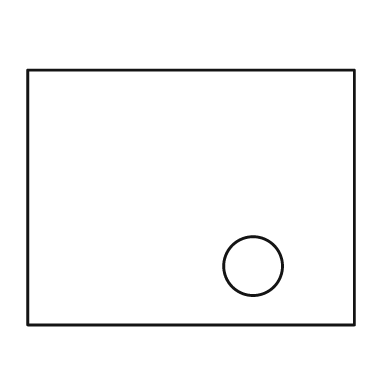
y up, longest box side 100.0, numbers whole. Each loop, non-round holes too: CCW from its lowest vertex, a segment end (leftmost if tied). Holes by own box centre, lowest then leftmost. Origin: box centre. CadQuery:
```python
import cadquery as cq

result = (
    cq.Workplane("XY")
    .moveTo(-50.0, -39.0)
    .lineTo(50.0, -39.0)
    .lineTo(50.0, 39.0)
    .lineTo(-50.0, 39.0)
    .close()
    .moveTo(19.0, -21.0)
    .circle(9.0)
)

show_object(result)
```